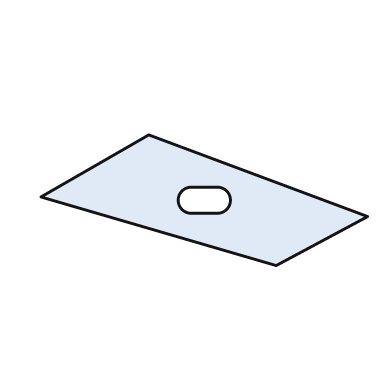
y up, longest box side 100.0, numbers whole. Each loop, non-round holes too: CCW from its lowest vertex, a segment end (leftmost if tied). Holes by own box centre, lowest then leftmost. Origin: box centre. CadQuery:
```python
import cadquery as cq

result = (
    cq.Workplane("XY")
    .moveTo(22.0, -20.0)
    .lineTo(50.0, -5.0)
    .lineTo(-17.0, 20.0)
    .lineTo(-50.0, 1.0)
    .close()
    .moveTo(-4.0, -4.0)
    .lineTo(4.0, -4.0)
    .threePointArc((8.0, 0.0), (4.0, 4.0))
    .lineTo(-4.0, 4.0)
    .threePointArc((-8.0, 0.0), (-4.0, -4.0))
    .close()
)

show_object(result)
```